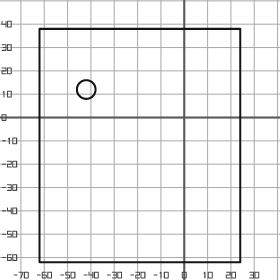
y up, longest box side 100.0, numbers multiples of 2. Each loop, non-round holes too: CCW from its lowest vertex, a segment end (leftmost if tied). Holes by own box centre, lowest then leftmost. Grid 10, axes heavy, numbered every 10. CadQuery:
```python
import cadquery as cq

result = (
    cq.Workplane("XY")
    .moveTo(-62.0, -62.0)
    .lineTo(24.0, -62.0)
    .lineTo(24.0, 38.0)
    .lineTo(-62.0, 38.0)
    .close()
    .moveTo(-42.0, 12.0)
    .circle(4.0)
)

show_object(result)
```